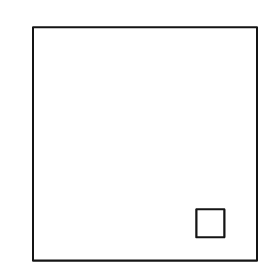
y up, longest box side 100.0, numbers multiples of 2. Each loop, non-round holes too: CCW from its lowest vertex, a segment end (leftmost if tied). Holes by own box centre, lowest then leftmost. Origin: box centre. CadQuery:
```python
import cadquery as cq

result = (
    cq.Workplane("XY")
    .moveTo(-48.0, -50.0)
    .lineTo(48.0, -50.0)
    .lineTo(48.0, 50.0)
    .lineTo(-48.0, 50.0)
    .close()
    .moveTo(22.0, -40.0)
    .lineTo(34.0, -40.0)
    .lineTo(34.0, -28.0)
    .lineTo(22.0, -28.0)
    .close()
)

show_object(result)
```